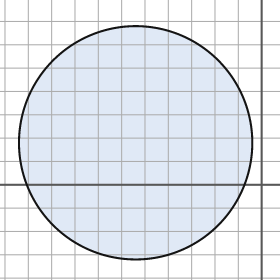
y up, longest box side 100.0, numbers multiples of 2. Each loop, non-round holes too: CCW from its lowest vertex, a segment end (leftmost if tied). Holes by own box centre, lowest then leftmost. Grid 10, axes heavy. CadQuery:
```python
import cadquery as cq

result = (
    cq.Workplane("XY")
    .moveTo(-54.0, 18.0)
    .circle(50.0)
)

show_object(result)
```